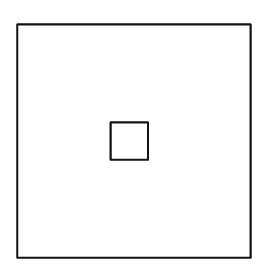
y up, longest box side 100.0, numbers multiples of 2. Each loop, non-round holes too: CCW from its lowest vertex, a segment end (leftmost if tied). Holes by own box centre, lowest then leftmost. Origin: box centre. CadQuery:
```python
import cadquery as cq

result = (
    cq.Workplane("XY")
    .moveTo(-50.0, -50.0)
    .lineTo(50.0, -50.0)
    .lineTo(50.0, 50.0)
    .lineTo(-50.0, 50.0)
    .close()
    .moveTo(-10.0, -8.0)
    .lineTo(6.0, -8.0)
    .lineTo(6.0, 8.0)
    .lineTo(-10.0, 8.0)
    .close()
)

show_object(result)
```